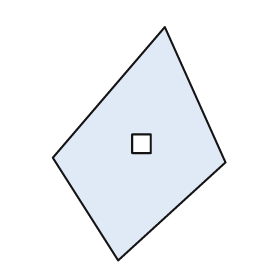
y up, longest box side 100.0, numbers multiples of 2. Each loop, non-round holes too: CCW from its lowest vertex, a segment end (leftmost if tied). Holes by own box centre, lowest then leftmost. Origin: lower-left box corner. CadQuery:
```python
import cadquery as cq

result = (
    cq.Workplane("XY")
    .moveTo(28.0, 0.0)
    .lineTo(74.0, 42.0)
    .lineTo(48.0, 100.0)
    .lineTo(0.0, 44.0)
    .close()
    .moveTo(34.0, 46.0)
    .lineTo(42.0, 46.0)
    .lineTo(42.0, 54.0)
    .lineTo(34.0, 54.0)
    .close()
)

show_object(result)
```